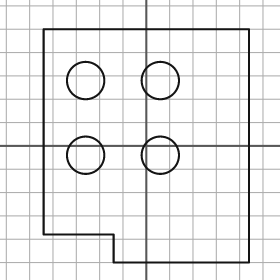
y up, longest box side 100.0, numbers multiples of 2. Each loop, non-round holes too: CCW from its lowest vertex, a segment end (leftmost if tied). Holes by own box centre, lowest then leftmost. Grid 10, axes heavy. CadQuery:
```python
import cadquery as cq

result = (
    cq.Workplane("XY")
    .moveTo(-14.0, -50.0)
    .lineTo(44.0, -50.0)
    .lineTo(44.0, 50.0)
    .lineTo(-44.0, 50.0)
    .lineTo(-44.0, -38.0)
    .lineTo(-14.0, -38.0)
    .close()
    .moveTo(-26.0, -4.0)
    .circle(8.0)
    .moveTo(6.0, -4.0)
    .circle(8.0)
    .moveTo(-26.0, 28.0)
    .circle(8.0)
    .moveTo(6.0, 28.0)
    .circle(8.0)
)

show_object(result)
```